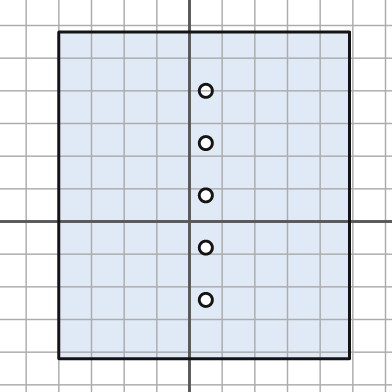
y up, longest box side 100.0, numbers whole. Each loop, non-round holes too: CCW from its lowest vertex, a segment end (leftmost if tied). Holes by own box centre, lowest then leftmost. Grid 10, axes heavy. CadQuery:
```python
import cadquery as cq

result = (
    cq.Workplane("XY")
    .moveTo(-40.0, -42.0)
    .lineTo(49.0, -42.0)
    .lineTo(49.0, 58.0)
    .lineTo(-40.0, 58.0)
    .close()
    .moveTo(5.0, -24.0)
    .circle(2.0)
    .moveTo(5.0, -8.0)
    .circle(2.0)
    .moveTo(5.0, 8.0)
    .circle(2.0)
    .moveTo(5.0, 24.0)
    .circle(2.0)
    .moveTo(5.0, 40.0)
    .circle(2.0)
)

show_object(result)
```